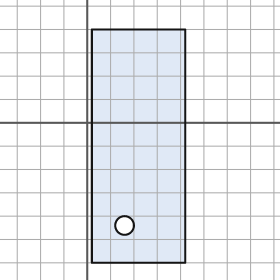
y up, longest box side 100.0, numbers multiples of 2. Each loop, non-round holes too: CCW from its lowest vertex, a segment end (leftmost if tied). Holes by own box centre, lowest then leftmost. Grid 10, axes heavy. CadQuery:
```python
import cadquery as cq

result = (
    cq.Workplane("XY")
    .moveTo(2.0, -60.0)
    .lineTo(42.0, -60.0)
    .lineTo(42.0, 40.0)
    .lineTo(2.0, 40.0)
    .close()
    .moveTo(16.0, -44.0)
    .circle(4.0)
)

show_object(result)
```